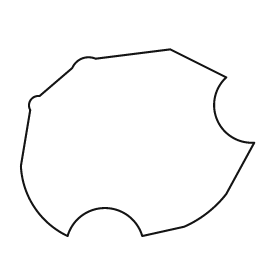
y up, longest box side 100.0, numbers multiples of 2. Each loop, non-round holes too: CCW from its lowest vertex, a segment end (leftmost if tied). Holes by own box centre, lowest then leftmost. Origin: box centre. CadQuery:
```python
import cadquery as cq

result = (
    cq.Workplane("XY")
    .moveTo(-30.0, -40.0)
    .threePointArc((-14.0, -28.0), (2.0, -40.0))
    .lineTo(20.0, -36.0)
    .threePointArc((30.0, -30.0), (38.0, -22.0))
    .lineTo(50.0, 0.0)
    .threePointArc((34.0, 10.0), (38.0, 28.0))
    .lineTo(14.0, 40.0)
    .lineTo(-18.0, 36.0)
    .threePointArc((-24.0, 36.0), (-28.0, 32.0))
    .lineTo(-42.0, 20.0)
    .threePointArc((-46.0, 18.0), (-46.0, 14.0))
    .lineTo(-50.0, -10.0)
    .threePointArc((-44.0, -28.0), (-30.0, -40.0))
    .close()
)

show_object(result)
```